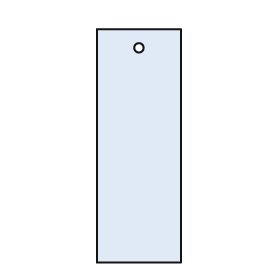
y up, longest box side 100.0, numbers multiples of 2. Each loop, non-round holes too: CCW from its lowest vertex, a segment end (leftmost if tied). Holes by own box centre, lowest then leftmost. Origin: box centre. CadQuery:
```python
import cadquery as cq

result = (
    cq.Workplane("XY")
    .moveTo(-18.0, -50.0)
    .lineTo(18.0, -50.0)
    .lineTo(18.0, 50.0)
    .lineTo(-18.0, 50.0)
    .close()
    .moveTo(0.0, 42.0)
    .circle(2.0)
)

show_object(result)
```